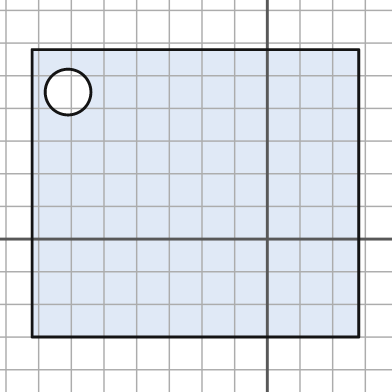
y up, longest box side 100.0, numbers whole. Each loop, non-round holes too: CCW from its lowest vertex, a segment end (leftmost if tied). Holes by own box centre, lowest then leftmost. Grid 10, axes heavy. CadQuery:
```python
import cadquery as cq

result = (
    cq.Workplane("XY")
    .moveTo(-72.0, -30.0)
    .lineTo(28.0, -30.0)
    .lineTo(28.0, 58.0)
    .lineTo(-72.0, 58.0)
    .close()
    .moveTo(-61.0, 45.0)
    .circle(7.0)
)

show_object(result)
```